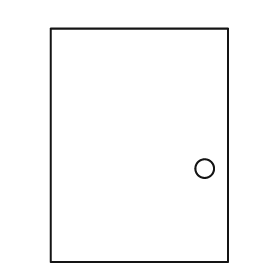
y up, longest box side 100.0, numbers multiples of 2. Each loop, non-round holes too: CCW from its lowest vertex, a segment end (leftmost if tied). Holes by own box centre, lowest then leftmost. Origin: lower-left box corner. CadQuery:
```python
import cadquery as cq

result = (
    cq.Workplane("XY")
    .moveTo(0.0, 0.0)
    .lineTo(76.0, 0.0)
    .lineTo(76.0, 100.0)
    .lineTo(0.0, 100.0)
    .close()
    .moveTo(66.0, 40.0)
    .circle(4.0)
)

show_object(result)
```